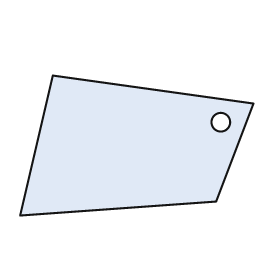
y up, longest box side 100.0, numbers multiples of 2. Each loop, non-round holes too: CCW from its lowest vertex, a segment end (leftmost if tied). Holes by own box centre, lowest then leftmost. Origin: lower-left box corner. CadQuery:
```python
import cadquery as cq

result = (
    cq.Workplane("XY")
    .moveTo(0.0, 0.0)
    .lineTo(84.0, 6.0)
    .lineTo(100.0, 48.0)
    .lineTo(14.0, 60.0)
    .close()
    .moveTo(86.0, 40.0)
    .circle(4.0)
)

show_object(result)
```